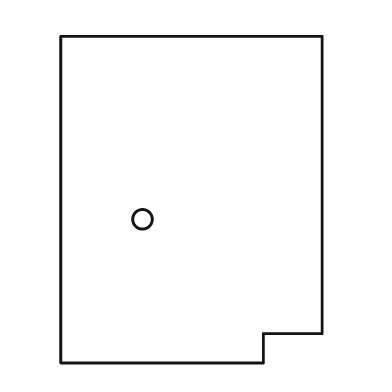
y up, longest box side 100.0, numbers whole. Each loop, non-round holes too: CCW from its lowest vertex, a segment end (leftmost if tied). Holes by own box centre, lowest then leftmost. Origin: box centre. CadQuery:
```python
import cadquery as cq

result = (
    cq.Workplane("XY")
    .moveTo(-40.0, -50.0)
    .lineTo(22.0, -50.0)
    .lineTo(22.0, -41.0)
    .lineTo(40.0, -41.0)
    .lineTo(40.0, 50.0)
    .lineTo(-40.0, 50.0)
    .close()
    .moveTo(-15.0, -6.0)
    .circle(3.0)
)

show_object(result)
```